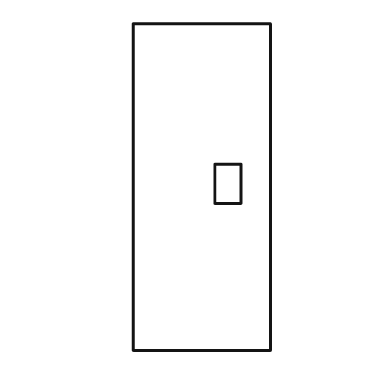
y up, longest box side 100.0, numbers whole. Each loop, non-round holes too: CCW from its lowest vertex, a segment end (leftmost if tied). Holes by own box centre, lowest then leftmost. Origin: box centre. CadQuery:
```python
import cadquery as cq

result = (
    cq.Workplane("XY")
    .moveTo(-21.0, -50.0)
    .lineTo(21.0, -50.0)
    .lineTo(21.0, 50.0)
    .lineTo(-21.0, 50.0)
    .close()
    .moveTo(4.0, -5.0)
    .lineTo(12.0, -5.0)
    .lineTo(12.0, 7.0)
    .lineTo(4.0, 7.0)
    .close()
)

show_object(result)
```